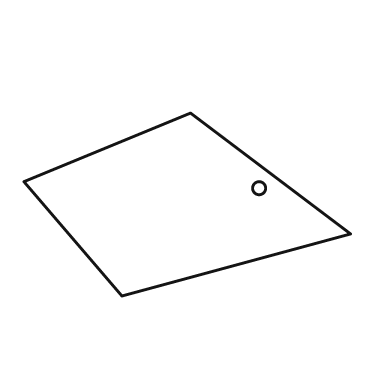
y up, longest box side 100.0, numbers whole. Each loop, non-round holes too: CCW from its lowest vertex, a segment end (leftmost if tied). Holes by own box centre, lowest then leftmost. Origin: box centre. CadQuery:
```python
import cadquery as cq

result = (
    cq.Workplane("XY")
    .moveTo(-20.0, -28.0)
    .lineTo(50.0, -9.0)
    .lineTo(1.0, 28.0)
    .lineTo(-50.0, 7.0)
    .close()
    .moveTo(22.0, 5.0)
    .circle(2.0)
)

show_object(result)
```